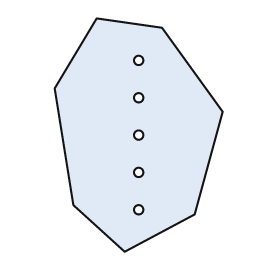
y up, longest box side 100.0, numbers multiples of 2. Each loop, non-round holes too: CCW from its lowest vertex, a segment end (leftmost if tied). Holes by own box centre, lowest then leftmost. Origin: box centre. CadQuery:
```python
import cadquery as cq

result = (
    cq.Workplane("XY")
    .moveTo(-6.0, -50.0)
    .lineTo(24.0, -34.0)
    .lineTo(36.0, 10.0)
    .lineTo(10.0, 46.0)
    .lineTo(-18.0, 50.0)
    .lineTo(-36.0, 20.0)
    .lineTo(-28.0, -30.0)
    .close()
    .moveTo(0.0, -32.0)
    .circle(2.0)
    .moveTo(0.0, -16.0)
    .circle(2.0)
    .moveTo(0.0, 0.0)
    .circle(2.0)
    .moveTo(0.0, 16.0)
    .circle(2.0)
    .moveTo(0.0, 32.0)
    .circle(2.0)
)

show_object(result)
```